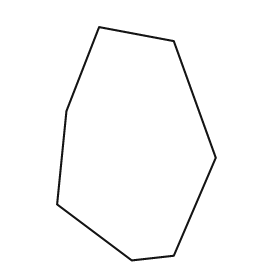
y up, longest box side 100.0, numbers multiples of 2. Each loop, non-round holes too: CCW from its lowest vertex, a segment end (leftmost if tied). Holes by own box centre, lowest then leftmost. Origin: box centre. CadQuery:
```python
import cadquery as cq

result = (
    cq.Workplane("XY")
    .moveTo(-2.0, -50.0)
    .lineTo(16.0, -48.0)
    .lineTo(34.0, -6.0)
    .lineTo(16.0, 44.0)
    .lineTo(-16.0, 50.0)
    .lineTo(-30.0, 14.0)
    .lineTo(-34.0, -26.0)
    .close()
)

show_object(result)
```